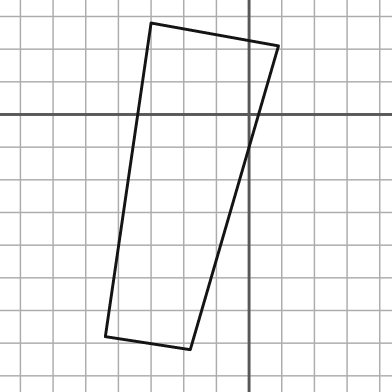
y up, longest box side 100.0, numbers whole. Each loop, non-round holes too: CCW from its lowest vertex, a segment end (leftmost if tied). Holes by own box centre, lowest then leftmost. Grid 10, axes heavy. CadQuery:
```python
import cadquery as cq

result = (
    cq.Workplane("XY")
    .moveTo(-18.0, -72.0)
    .lineTo(9.0, 21.0)
    .lineTo(-30.0, 28.0)
    .lineTo(-44.0, -68.0)
    .close()
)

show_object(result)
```